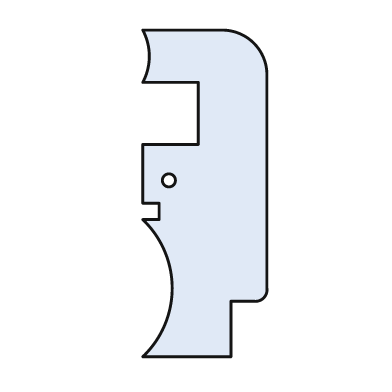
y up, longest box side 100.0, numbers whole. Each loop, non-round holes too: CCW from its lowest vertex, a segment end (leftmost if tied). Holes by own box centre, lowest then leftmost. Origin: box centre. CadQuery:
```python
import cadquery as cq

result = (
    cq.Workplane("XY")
    .moveTo(-19.0, -50.0)
    .lineTo(8.0, -50.0)
    .lineTo(8.0, -33.0)
    .lineTo(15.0, -33.0)
    .threePointArc((18.0, -32.0), (19.0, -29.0))
    .lineTo(19.0, 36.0)
    .threePointArc((15.0, 46.0), (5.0, 50.0))
    .lineTo(-19.0, 50.0)
    .threePointArc((-17.0, 42.0), (-19.0, 34.0))
    .lineTo(-2.0, 34.0)
    .lineTo(-2.0, 15.0)
    .lineTo(-19.0, 15.0)
    .lineTo(-19.0, -3.0)
    .lineTo(-14.0, -3.0)
    .lineTo(-14.0, -8.0)
    .lineTo(-19.0, -8.0)
    .threePointArc((-10.0, -29.0), (-19.0, -50.0))
    .close()
    .moveTo(-11.0, 4.0)
    .circle(2.0)
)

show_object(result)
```